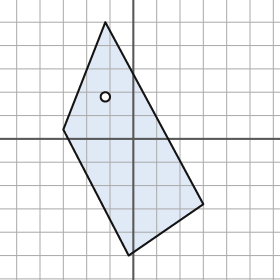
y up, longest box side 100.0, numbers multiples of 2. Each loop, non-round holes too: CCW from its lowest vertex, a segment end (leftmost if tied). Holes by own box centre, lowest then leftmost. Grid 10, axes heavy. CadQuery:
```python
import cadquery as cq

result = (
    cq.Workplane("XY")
    .moveTo(-2.0, -50.0)
    .lineTo(30.0, -28.0)
    .lineTo(-12.0, 50.0)
    .lineTo(-30.0, 4.0)
    .close()
    .moveTo(-12.0, 18.0)
    .circle(2.0)
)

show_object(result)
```